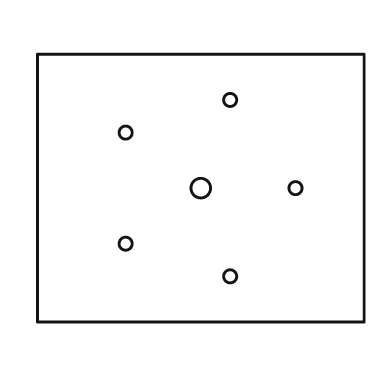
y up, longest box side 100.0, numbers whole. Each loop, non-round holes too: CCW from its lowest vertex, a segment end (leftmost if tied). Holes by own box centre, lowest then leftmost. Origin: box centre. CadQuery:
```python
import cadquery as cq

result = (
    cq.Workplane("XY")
    .moveTo(-50.0, -41.0)
    .lineTo(50.0, -41.0)
    .lineTo(50.0, 41.0)
    .lineTo(-50.0, 41.0)
    .close()
    .moveTo(9.0, -27.0)
    .circle(2.0)
    .moveTo(-23.0, -17.0)
    .circle(2.0)
    .moveTo(0.0, 0.0)
    .circle(3.0)
    .moveTo(29.0, 0.0)
    .circle(2.0)
    .moveTo(-23.0, 17.0)
    .circle(2.0)
    .moveTo(9.0, 27.0)
    .circle(2.0)
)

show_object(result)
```